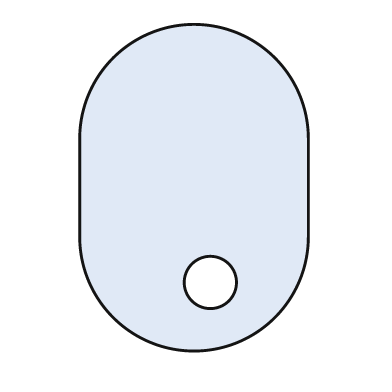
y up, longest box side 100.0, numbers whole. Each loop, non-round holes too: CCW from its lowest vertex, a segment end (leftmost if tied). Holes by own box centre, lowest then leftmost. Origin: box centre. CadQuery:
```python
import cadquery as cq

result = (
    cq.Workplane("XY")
    .moveTo(-35.0, -15.0)
    .threePointArc((0.0, -50.0), (35.0, -15.0))
    .lineTo(35.0, 15.0)
    .threePointArc((0.0, 50.0), (-35.0, 15.0))
    .close()
    .moveTo(5.0, -29.0)
    .circle(8.0)
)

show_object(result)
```